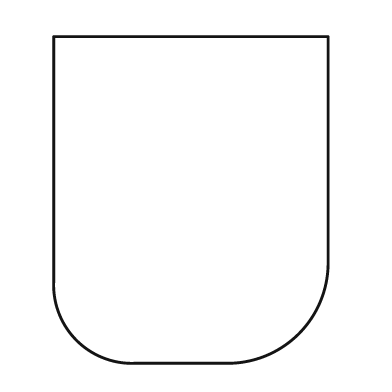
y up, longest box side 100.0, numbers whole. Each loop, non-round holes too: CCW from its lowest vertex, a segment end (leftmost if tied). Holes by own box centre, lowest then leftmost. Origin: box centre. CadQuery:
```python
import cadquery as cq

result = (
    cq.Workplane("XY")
    .moveTo(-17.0, -50.0)
    .lineTo(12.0, -50.0)
    .threePointArc((33.0, -41.0), (42.0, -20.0))
    .lineTo(42.0, 50.0)
    .lineTo(-42.0, 50.0)
    .lineTo(-42.0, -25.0)
    .threePointArc((-35.0, -43.0), (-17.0, -50.0))
    .close()
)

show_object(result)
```